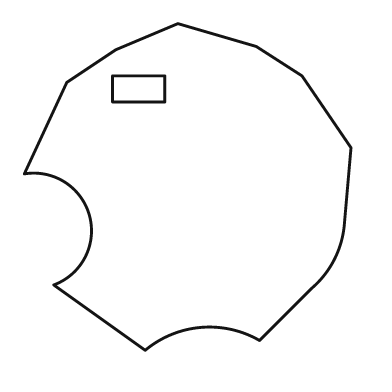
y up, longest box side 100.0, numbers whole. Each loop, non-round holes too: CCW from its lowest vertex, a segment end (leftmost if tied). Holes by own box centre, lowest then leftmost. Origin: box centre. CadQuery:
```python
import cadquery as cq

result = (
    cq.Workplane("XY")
    .moveTo(-13.0, -50.0)
    .threePointArc((4.0, -43.0), (22.0, -47.0))
    .lineTo(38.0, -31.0)
    .threePointArc((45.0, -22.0), (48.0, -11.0))
    .lineTo(50.0, 12.0)
    .lineTo(35.0, 34.0)
    .lineTo(21.0, 43.0)
    .lineTo(-3.0, 50.0)
    .lineTo(-22.0, 42.0)
    .lineTo(-37.0, 32.0)
    .lineTo(-50.0, 4.0)
    .threePointArc((-30.0, -9.0), (-41.0, -30.0))
    .close()
    .moveTo(-23.0, 26.0)
    .lineTo(-7.0, 26.0)
    .lineTo(-7.0, 34.0)
    .lineTo(-23.0, 34.0)
    .close()
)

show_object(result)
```